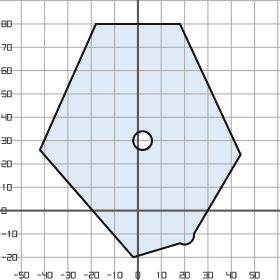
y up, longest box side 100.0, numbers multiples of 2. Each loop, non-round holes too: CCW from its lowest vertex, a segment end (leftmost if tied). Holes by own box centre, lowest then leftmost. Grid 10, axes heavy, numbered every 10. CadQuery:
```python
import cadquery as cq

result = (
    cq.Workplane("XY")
    .moveTo(-2.0, -20.0)
    .lineTo(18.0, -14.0)
    .threePointArc((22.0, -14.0), (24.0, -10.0))
    .lineTo(44.0, 24.0)
    .lineTo(18.0, 80.0)
    .lineTo(-18.0, 80.0)
    .lineTo(-42.0, 26.0)
    .close()
    .moveTo(2.0, 30.0)
    .circle(4.0)
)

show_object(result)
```